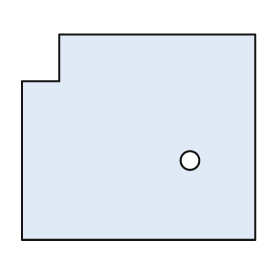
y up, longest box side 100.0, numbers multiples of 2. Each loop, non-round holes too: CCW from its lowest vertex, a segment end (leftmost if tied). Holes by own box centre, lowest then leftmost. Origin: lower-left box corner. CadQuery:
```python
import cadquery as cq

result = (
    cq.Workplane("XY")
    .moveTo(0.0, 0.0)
    .lineTo(100.0, 0.0)
    .lineTo(100.0, 88.0)
    .lineTo(16.0, 88.0)
    .lineTo(16.0, 68.0)
    .lineTo(0.0, 68.0)
    .close()
    .moveTo(72.0, 34.0)
    .circle(4.0)
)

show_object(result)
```